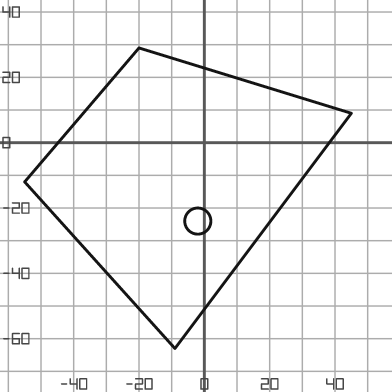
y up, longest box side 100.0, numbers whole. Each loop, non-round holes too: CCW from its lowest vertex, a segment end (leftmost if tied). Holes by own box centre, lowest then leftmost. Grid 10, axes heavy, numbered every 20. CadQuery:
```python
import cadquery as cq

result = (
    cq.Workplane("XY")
    .moveTo(-9.0, -63.0)
    .lineTo(45.0, 9.0)
    .lineTo(-20.0, 29.0)
    .lineTo(-55.0, -12.0)
    .close()
    .moveTo(-2.0, -24.0)
    .circle(4.0)
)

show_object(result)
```